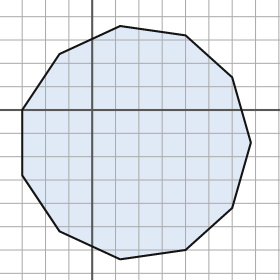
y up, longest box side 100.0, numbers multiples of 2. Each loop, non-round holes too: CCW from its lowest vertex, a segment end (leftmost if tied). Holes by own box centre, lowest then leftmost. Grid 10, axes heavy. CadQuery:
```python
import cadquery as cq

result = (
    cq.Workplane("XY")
    .moveTo(12.0, -64.0)
    .lineTo(40.0, -60.0)
    .lineTo(60.0, -42.0)
    .lineTo(68.0, -14.0)
    .lineTo(60.0, 14.0)
    .lineTo(40.0, 32.0)
    .lineTo(12.0, 36.0)
    .lineTo(-14.0, 24.0)
    .lineTo(-30.0, 0.0)
    .lineTo(-30.0, -28.0)
    .lineTo(-14.0, -52.0)
    .close()
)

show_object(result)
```